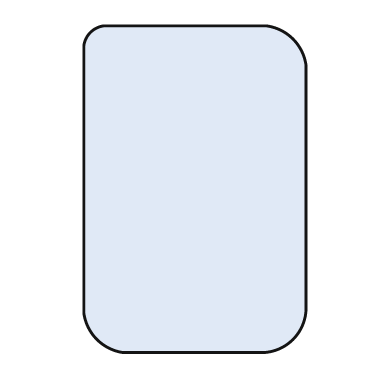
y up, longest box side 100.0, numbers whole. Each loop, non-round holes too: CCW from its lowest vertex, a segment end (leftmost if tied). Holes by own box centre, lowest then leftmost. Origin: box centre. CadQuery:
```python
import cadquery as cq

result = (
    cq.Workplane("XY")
    .moveTo(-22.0, -50.0)
    .lineTo(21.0, -50.0)
    .threePointArc((30.0, -46.0), (34.0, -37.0))
    .lineTo(34.0, 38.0)
    .threePointArc((30.0, 46.0), (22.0, 50.0))
    .lineTo(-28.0, 50.0)
    .threePointArc((-32.0, 48.0), (-34.0, 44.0))
    .lineTo(-34.0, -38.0)
    .threePointArc((-30.0, -46.0), (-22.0, -50.0))
    .close()
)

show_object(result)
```